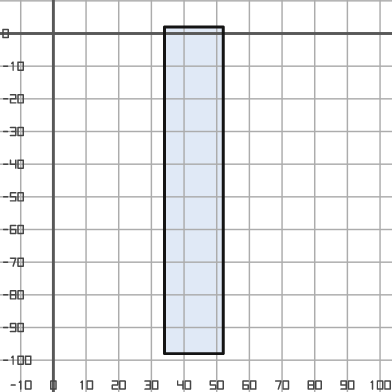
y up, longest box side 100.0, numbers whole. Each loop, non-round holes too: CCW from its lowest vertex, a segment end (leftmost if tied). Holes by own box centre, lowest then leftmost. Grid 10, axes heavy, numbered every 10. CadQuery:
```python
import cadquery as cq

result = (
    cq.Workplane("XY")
    .moveTo(34.0, -98.0)
    .lineTo(52.0, -98.0)
    .lineTo(52.0, 2.0)
    .lineTo(34.0, 2.0)
    .close()
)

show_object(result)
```